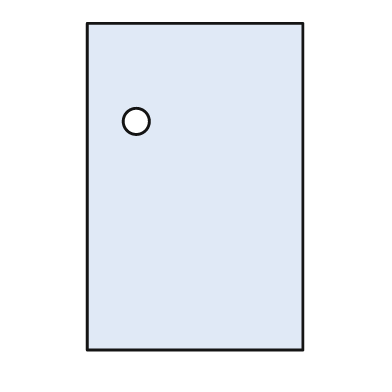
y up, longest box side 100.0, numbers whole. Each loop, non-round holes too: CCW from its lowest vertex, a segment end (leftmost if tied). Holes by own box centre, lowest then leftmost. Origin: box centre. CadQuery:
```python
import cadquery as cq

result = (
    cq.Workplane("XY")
    .moveTo(-33.0, -50.0)
    .lineTo(33.0, -50.0)
    .lineTo(33.0, 50.0)
    .lineTo(-33.0, 50.0)
    .close()
    .moveTo(-18.0, 20.0)
    .circle(4.0)
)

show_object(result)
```